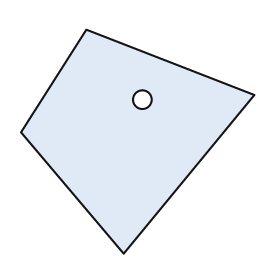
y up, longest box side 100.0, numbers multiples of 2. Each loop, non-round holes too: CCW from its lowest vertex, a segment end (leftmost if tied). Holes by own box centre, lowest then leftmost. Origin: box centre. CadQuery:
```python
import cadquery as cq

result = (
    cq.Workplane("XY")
    .moveTo(-6.0, -48.0)
    .lineTo(50.0, 20.0)
    .lineTo(-22.0, 48.0)
    .lineTo(-50.0, 4.0)
    .close()
    .moveTo(2.0, 18.0)
    .circle(4.0)
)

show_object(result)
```